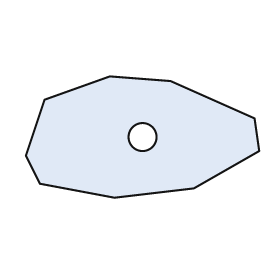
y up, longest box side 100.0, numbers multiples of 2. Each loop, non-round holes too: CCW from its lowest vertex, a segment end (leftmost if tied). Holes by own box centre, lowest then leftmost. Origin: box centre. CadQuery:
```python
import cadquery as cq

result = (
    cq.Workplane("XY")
    .moveTo(-12.0, -26.0)
    .lineTo(22.0, -22.0)
    .lineTo(50.0, -6.0)
    .lineTo(48.0, 8.0)
    .lineTo(12.0, 24.0)
    .lineTo(-14.0, 26.0)
    .lineTo(-42.0, 16.0)
    .lineTo(-50.0, -8.0)
    .lineTo(-44.0, -20.0)
    .close()
    .moveTo(0.0, 0.0)
    .circle(6.0)
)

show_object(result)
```